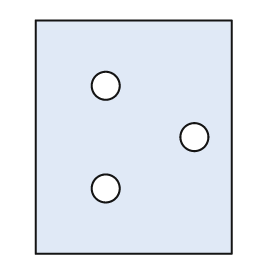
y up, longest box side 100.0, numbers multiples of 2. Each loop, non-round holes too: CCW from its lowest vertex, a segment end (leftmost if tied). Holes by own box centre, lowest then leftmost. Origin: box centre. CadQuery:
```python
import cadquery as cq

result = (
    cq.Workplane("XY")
    .moveTo(-42.0, -50.0)
    .lineTo(42.0, -50.0)
    .lineTo(42.0, 50.0)
    .lineTo(-42.0, 50.0)
    .close()
    .moveTo(-12.0, -22.0)
    .circle(6.0)
    .moveTo(26.0, 0.0)
    .circle(6.0)
    .moveTo(-12.0, 22.0)
    .circle(6.0)
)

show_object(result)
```